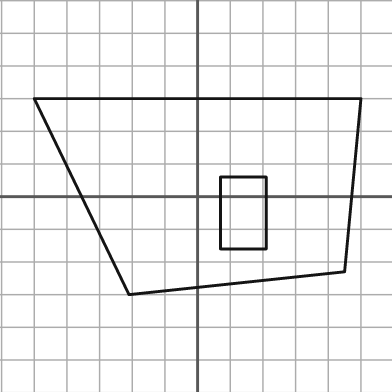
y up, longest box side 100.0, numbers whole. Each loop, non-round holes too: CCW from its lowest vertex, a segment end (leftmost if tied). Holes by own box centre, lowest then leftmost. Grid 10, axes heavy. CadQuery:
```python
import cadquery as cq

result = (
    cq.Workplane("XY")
    .moveTo(-21.0, -30.0)
    .lineTo(45.0, -23.0)
    .lineTo(50.0, 30.0)
    .lineTo(-50.0, 30.0)
    .close()
    .moveTo(7.0, -16.0)
    .lineTo(21.0, -16.0)
    .lineTo(21.0, 6.0)
    .lineTo(7.0, 6.0)
    .close()
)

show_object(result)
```